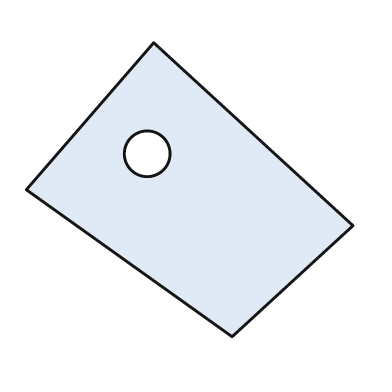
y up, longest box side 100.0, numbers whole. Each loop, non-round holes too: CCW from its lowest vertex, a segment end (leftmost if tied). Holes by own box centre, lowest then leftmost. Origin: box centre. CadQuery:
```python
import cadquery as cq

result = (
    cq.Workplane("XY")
    .moveTo(13.0, -45.0)
    .lineTo(50.0, -11.0)
    .lineTo(-11.0, 45.0)
    .lineTo(-50.0, 0.0)
    .close()
    .moveTo(-13.0, 11.0)
    .circle(7.0)
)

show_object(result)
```